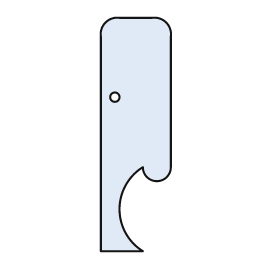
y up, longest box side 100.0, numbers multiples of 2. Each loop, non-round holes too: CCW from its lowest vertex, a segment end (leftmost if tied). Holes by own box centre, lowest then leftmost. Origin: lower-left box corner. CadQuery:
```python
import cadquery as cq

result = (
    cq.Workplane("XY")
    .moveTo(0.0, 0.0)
    .lineTo(18.0, 0.0)
    .threePointArc((8.0, 18.0), (18.0, 36.0))
    .threePointArc((24.0, 30.0), (30.0, 36.0))
    .lineTo(30.0, 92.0)
    .threePointArc((28.0, 98.0), (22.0, 100.0))
    .lineTo(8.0, 100.0)
    .threePointArc((2.0, 98.0), (0.0, 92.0))
    .close()
    .moveTo(6.0, 66.0)
    .circle(2.0)
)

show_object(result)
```